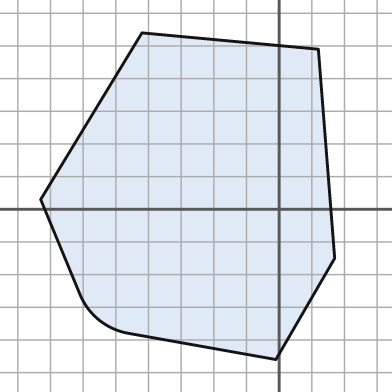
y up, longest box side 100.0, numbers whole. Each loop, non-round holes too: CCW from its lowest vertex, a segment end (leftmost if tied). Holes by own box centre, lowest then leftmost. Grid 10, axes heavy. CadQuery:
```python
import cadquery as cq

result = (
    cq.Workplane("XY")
    .moveTo(-1.0, -46.0)
    .lineTo(17.0, -15.0)
    .lineTo(12.0, 49.0)
    .lineTo(-42.0, 54.0)
    .lineTo(-73.0, 3.0)
    .lineTo(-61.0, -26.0)
    .threePointArc((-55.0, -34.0), (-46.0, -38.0))
    .close()
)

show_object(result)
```